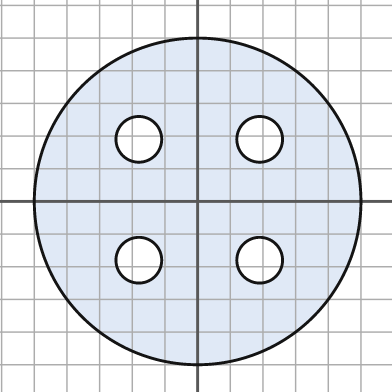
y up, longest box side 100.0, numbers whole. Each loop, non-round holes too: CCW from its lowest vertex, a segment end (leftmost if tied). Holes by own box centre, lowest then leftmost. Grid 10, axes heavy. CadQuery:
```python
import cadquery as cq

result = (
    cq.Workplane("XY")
    .moveTo(0.0, 0.0)
    .circle(50.0)
    .moveTo(-18.0, -18.0)
    .circle(7.0)
    .moveTo(19.0, -18.0)
    .circle(7.0)
    .moveTo(-18.0, 19.0)
    .circle(7.0)
    .moveTo(19.0, 19.0)
    .circle(7.0)
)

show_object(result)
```